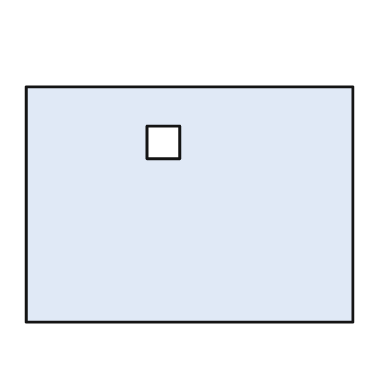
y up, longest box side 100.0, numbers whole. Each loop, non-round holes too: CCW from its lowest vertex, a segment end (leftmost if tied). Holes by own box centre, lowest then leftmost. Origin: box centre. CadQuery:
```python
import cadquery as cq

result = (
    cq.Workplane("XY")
    .moveTo(-50.0, -36.0)
    .lineTo(50.0, -36.0)
    .lineTo(50.0, 36.0)
    .lineTo(-50.0, 36.0)
    .close()
    .moveTo(-13.0, 14.0)
    .lineTo(-3.0, 14.0)
    .lineTo(-3.0, 24.0)
    .lineTo(-13.0, 24.0)
    .close()
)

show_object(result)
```